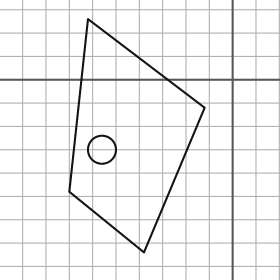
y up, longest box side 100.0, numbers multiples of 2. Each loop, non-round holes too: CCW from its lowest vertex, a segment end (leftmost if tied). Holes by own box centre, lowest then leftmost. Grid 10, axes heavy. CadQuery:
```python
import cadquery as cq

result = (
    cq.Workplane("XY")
    .moveTo(-38.0, -74.0)
    .lineTo(-12.0, -12.0)
    .lineTo(-62.0, 26.0)
    .lineTo(-70.0, -48.0)
    .close()
    .moveTo(-56.0, -30.0)
    .circle(6.0)
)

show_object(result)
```